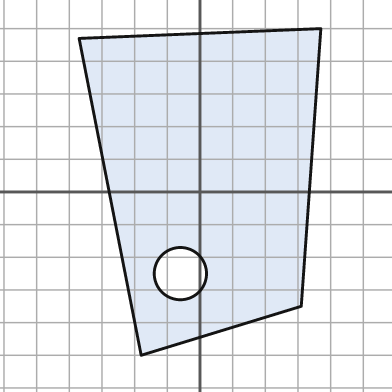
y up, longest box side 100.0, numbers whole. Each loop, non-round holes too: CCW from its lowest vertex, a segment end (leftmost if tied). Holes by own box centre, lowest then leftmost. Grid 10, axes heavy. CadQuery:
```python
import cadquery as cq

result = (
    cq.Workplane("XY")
    .moveTo(-18.0, -50.0)
    .lineTo(31.0, -35.0)
    .lineTo(37.0, 50.0)
    .lineTo(-37.0, 47.0)
    .close()
    .moveTo(-6.0, -25.0)
    .circle(8.0)
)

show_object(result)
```